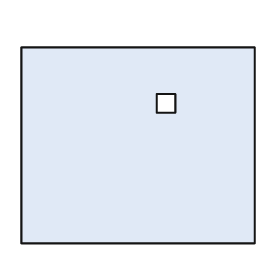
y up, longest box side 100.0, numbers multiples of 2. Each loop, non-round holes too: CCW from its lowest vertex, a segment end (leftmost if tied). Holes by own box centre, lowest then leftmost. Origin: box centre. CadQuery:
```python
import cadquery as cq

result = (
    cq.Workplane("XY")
    .moveTo(-50.0, -42.0)
    .lineTo(50.0, -42.0)
    .lineTo(50.0, 42.0)
    .lineTo(-50.0, 42.0)
    .close()
    .moveTo(8.0, 14.0)
    .lineTo(16.0, 14.0)
    .lineTo(16.0, 22.0)
    .lineTo(8.0, 22.0)
    .close()
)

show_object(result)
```